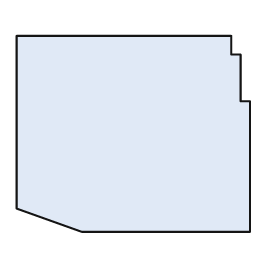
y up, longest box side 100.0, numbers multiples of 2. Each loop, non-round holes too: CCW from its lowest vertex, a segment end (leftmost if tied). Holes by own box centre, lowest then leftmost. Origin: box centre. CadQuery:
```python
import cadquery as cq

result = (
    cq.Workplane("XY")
    .moveTo(-22.0, -42.0)
    .lineTo(50.0, -42.0)
    .lineTo(50.0, 14.0)
    .lineTo(46.0, 14.0)
    .lineTo(46.0, 34.0)
    .lineTo(42.0, 34.0)
    .lineTo(42.0, 42.0)
    .lineTo(-50.0, 42.0)
    .lineTo(-50.0, -32.0)
    .close()
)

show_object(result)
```